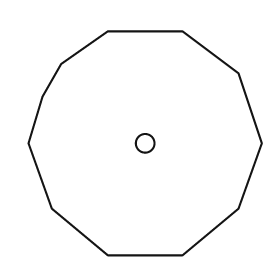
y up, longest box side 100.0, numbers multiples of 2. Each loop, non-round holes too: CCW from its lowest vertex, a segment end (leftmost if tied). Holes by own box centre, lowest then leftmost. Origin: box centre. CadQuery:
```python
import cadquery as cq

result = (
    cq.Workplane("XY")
    .moveTo(-16.0, -48.0)
    .lineTo(16.0, -48.0)
    .lineTo(40.0, -28.0)
    .lineTo(50.0, 0.0)
    .lineTo(40.0, 30.0)
    .lineTo(16.0, 48.0)
    .lineTo(-16.0, 48.0)
    .lineTo(-36.0, 34.0)
    .lineTo(-44.0, 20.0)
    .lineTo(-50.0, 0.0)
    .lineTo(-40.0, -28.0)
    .close()
    .moveTo(0.0, 0.0)
    .circle(4.0)
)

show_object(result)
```